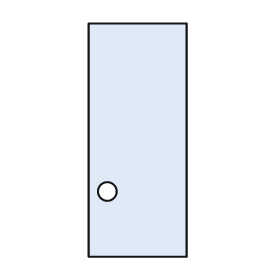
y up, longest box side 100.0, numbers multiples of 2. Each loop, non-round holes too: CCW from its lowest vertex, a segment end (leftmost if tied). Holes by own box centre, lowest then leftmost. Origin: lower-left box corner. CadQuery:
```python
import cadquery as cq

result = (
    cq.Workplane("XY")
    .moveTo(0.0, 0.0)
    .lineTo(42.0, 0.0)
    .lineTo(42.0, 100.0)
    .lineTo(0.0, 100.0)
    .close()
    .moveTo(8.0, 28.0)
    .circle(4.0)
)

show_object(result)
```